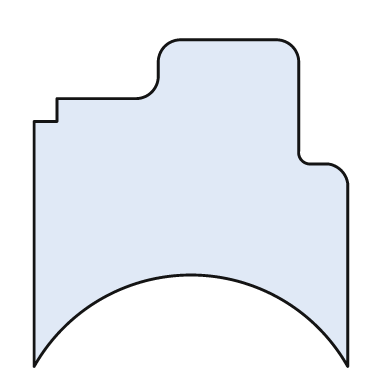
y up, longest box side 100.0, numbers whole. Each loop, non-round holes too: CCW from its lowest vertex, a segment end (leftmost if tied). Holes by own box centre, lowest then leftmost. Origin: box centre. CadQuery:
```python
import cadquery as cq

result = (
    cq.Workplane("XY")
    .moveTo(-48.0, -50.0)
    .threePointArc((0.0, -22.0), (48.0, -50.0))
    .lineTo(48.0, 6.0)
    .threePointArc((46.0, 10.0), (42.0, 12.0))
    .lineTo(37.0, 12.0)
    .threePointArc((34.0, 13.0), (33.0, 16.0))
    .lineTo(33.0, 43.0)
    .threePointArc((31.0, 48.0), (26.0, 50.0))
    .lineTo(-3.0, 50.0)
    .threePointArc((-8.0, 48.0), (-10.0, 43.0))
    .lineTo(-10.0, 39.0)
    .threePointArc((-12.0, 34.0), (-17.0, 32.0))
    .lineTo(-41.0, 32.0)
    .lineTo(-41.0, 25.0)
    .lineTo(-48.0, 25.0)
    .close()
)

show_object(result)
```